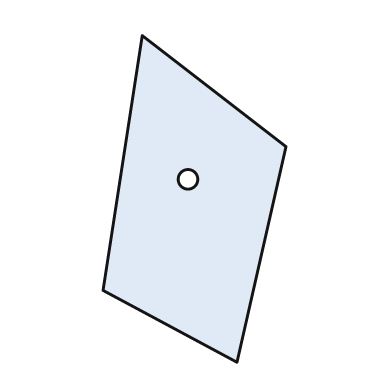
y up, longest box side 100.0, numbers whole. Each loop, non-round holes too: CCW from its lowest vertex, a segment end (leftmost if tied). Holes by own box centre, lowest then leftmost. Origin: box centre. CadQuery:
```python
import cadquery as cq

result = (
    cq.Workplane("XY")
    .moveTo(13.0, -50.0)
    .lineTo(28.0, 16.0)
    .lineTo(-16.0, 50.0)
    .lineTo(-28.0, -28.0)
    .close()
    .moveTo(-2.0, 6.0)
    .circle(3.0)
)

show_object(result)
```